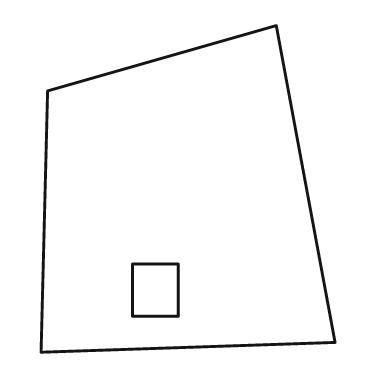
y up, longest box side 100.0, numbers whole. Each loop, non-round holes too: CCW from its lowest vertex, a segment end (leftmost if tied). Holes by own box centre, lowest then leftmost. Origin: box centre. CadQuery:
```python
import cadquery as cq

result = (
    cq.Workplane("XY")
    .moveTo(-45.0, -50.0)
    .lineTo(45.0, -47.0)
    .lineTo(27.0, 50.0)
    .lineTo(-43.0, 30.0)
    .close()
    .moveTo(-17.0, -39.0)
    .lineTo(-3.0, -39.0)
    .lineTo(-3.0, -23.0)
    .lineTo(-17.0, -23.0)
    .close()
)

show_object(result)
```